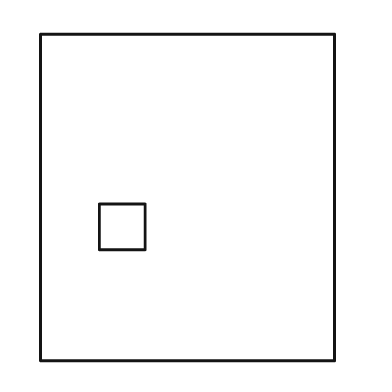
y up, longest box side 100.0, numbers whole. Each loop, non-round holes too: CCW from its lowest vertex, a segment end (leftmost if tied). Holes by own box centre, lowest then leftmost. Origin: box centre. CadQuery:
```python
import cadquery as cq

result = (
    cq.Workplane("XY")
    .moveTo(-45.0, -50.0)
    .lineTo(45.0, -50.0)
    .lineTo(45.0, 50.0)
    .lineTo(-45.0, 50.0)
    .close()
    .moveTo(-27.0, -16.0)
    .lineTo(-13.0, -16.0)
    .lineTo(-13.0, -2.0)
    .lineTo(-27.0, -2.0)
    .close()
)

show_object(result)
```